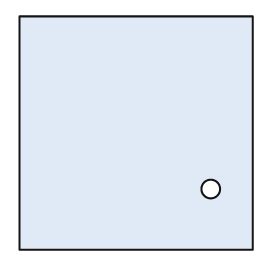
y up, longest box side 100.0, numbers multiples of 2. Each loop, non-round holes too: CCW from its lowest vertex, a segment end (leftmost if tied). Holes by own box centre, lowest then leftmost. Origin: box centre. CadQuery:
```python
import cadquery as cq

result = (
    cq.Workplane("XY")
    .moveTo(-50.0, -50.0)
    .lineTo(50.0, -50.0)
    .lineTo(50.0, 50.0)
    .lineTo(-50.0, 50.0)
    .close()
    .moveTo(32.0, -24.0)
    .circle(4.0)
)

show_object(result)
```